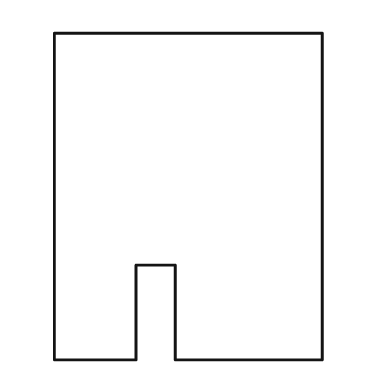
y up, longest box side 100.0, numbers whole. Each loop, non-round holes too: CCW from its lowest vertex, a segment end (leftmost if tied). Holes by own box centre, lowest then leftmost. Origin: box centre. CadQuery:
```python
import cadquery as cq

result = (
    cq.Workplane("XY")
    .moveTo(-41.0, -50.0)
    .lineTo(-16.0, -50.0)
    .lineTo(-16.0, -21.0)
    .lineTo(-4.0, -21.0)
    .lineTo(-4.0, -50.0)
    .lineTo(41.0, -50.0)
    .lineTo(41.0, 50.0)
    .lineTo(-41.0, 50.0)
    .close()
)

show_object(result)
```